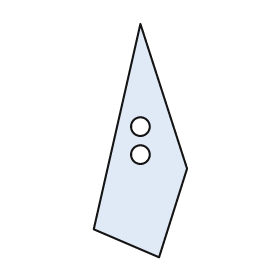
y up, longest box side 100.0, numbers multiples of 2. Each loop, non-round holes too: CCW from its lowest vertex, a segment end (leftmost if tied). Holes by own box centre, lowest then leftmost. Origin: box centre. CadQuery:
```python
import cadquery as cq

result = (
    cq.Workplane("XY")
    .moveTo(8.0, -50.0)
    .lineTo(20.0, -12.0)
    .lineTo(0.0, 50.0)
    .lineTo(-20.0, -38.0)
    .close()
    .moveTo(0.0, -6.0)
    .circle(4.0)
    .moveTo(0.0, 6.0)
    .circle(4.0)
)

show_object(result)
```